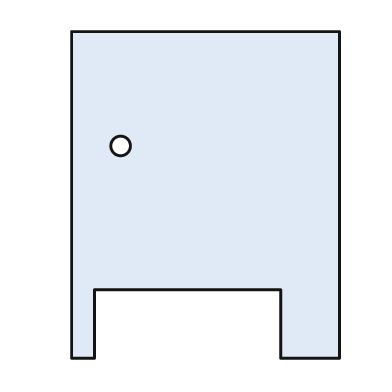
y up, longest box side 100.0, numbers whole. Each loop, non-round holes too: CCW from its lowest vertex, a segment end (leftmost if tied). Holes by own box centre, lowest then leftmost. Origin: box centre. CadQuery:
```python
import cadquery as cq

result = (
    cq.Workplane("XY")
    .moveTo(-41.0, -50.0)
    .lineTo(-34.0, -50.0)
    .lineTo(-34.0, -29.0)
    .lineTo(23.0, -29.0)
    .lineTo(23.0, -50.0)
    .lineTo(41.0, -50.0)
    .lineTo(41.0, 50.0)
    .lineTo(-41.0, 50.0)
    .close()
    .moveTo(-26.0, 15.0)
    .circle(3.0)
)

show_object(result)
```